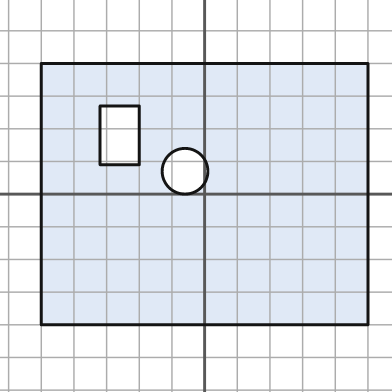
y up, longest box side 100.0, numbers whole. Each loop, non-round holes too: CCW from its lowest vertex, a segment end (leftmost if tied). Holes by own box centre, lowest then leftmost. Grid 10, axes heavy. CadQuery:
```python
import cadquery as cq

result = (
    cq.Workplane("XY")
    .moveTo(-50.0, -40.0)
    .lineTo(50.0, -40.0)
    .lineTo(50.0, 40.0)
    .lineTo(-50.0, 40.0)
    .close()
    .moveTo(-6.0, 7.0)
    .circle(7.0)
    .moveTo(-32.0, 9.0)
    .lineTo(-20.0, 9.0)
    .lineTo(-20.0, 27.0)
    .lineTo(-32.0, 27.0)
    .close()
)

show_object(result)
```